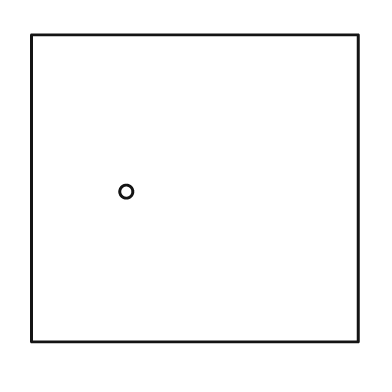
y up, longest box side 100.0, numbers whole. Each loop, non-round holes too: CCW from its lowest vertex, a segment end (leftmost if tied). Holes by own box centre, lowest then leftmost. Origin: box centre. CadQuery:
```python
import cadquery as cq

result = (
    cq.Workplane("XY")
    .moveTo(-50.0, -47.0)
    .lineTo(50.0, -47.0)
    .lineTo(50.0, 47.0)
    .lineTo(-50.0, 47.0)
    .close()
    .moveTo(-21.0, -1.0)
    .circle(2.0)
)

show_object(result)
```